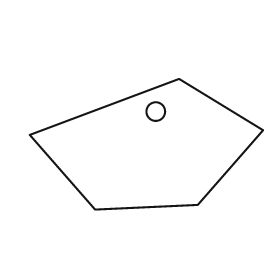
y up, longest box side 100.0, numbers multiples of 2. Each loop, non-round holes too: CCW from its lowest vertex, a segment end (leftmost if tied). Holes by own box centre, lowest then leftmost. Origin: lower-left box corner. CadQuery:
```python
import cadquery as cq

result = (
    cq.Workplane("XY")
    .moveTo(28.0, 0.0)
    .lineTo(72.0, 2.0)
    .lineTo(100.0, 34.0)
    .lineTo(64.0, 56.0)
    .lineTo(0.0, 32.0)
    .close()
    .moveTo(54.0, 42.0)
    .circle(4.0)
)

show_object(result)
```